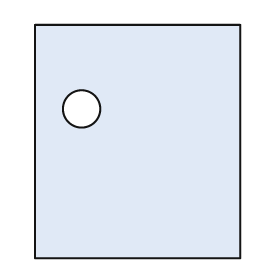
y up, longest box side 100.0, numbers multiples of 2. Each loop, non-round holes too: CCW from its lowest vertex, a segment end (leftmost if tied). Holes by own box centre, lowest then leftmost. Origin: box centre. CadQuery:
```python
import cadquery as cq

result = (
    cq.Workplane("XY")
    .moveTo(-44.0, -50.0)
    .lineTo(44.0, -50.0)
    .lineTo(44.0, 50.0)
    .lineTo(-44.0, 50.0)
    .close()
    .moveTo(-24.0, 14.0)
    .circle(8.0)
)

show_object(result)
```